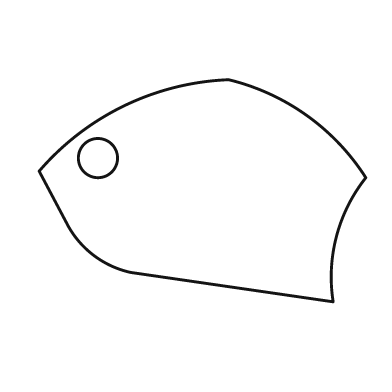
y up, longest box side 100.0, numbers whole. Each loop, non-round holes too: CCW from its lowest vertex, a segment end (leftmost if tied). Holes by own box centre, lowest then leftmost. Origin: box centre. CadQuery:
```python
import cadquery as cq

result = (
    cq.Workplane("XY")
    .moveTo(40.0, -34.0)
    .threePointArc((41.0, -14.0), (50.0, 4.0))
    .threePointArc((32.0, 23.0), (8.0, 34.0))
    .threePointArc((-24.0, 26.0), (-50.0, 6.0))
    .lineTo(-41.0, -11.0)
    .threePointArc((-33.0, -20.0), (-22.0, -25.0))
    .close()
    .moveTo(-32.0, 10.0)
    .circle(6.0)
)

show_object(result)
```